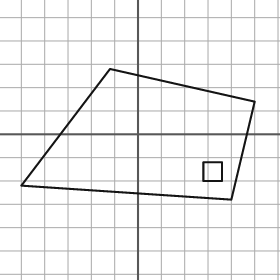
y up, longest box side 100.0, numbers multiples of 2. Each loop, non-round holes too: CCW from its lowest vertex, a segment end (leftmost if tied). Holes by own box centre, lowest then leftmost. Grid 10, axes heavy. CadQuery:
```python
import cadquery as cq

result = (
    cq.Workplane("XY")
    .moveTo(40.0, -28.0)
    .lineTo(50.0, 14.0)
    .lineTo(-12.0, 28.0)
    .lineTo(-50.0, -22.0)
    .close()
    .moveTo(28.0, -20.0)
    .lineTo(36.0, -20.0)
    .lineTo(36.0, -12.0)
    .lineTo(28.0, -12.0)
    .close()
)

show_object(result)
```